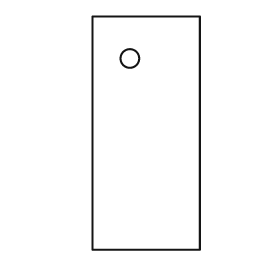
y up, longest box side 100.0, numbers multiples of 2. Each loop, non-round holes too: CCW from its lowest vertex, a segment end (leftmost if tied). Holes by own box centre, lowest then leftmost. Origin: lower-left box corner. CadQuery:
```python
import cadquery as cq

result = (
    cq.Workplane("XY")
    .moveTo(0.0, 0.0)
    .lineTo(46.0, 0.0)
    .lineTo(46.0, 100.0)
    .lineTo(0.0, 100.0)
    .close()
    .moveTo(16.0, 82.0)
    .circle(4.0)
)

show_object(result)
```